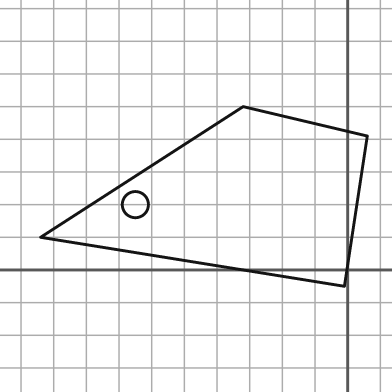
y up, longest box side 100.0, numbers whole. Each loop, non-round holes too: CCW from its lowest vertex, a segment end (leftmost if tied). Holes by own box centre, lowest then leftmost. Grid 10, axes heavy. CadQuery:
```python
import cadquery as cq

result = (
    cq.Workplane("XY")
    .moveTo(-1.0, -5.0)
    .lineTo(6.0, 41.0)
    .lineTo(-32.0, 50.0)
    .lineTo(-94.0, 10.0)
    .close()
    .moveTo(-65.0, 20.0)
    .circle(4.0)
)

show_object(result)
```